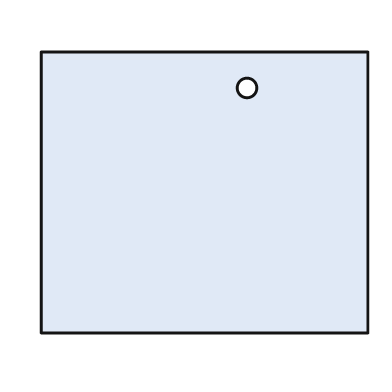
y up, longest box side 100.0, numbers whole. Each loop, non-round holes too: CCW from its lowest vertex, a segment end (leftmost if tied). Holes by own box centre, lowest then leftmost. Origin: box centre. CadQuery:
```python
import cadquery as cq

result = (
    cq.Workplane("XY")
    .moveTo(-50.0, -43.0)
    .lineTo(50.0, -43.0)
    .lineTo(50.0, 43.0)
    .lineTo(-50.0, 43.0)
    .close()
    .moveTo(13.0, 32.0)
    .circle(3.0)
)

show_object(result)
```